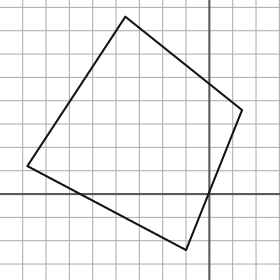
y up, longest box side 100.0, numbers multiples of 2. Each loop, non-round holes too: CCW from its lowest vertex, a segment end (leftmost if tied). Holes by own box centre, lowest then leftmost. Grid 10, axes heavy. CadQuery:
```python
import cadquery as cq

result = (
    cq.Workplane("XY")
    .moveTo(-10.0, -24.0)
    .lineTo(14.0, 36.0)
    .lineTo(-36.0, 76.0)
    .lineTo(-78.0, 12.0)
    .close()
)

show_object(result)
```